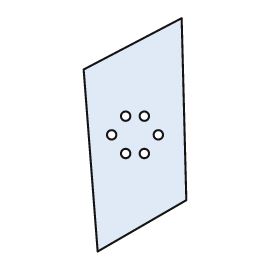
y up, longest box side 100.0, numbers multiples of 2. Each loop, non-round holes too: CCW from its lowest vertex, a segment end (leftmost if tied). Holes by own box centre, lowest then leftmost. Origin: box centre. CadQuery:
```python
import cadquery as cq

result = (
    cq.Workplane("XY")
    .moveTo(-16.0, -50.0)
    .lineTo(22.0, -28.0)
    .lineTo(20.0, 50.0)
    .lineTo(-22.0, 28.0)
    .close()
    .moveTo(-4.0, -8.0)
    .circle(2.0)
    .moveTo(4.0, -8.0)
    .circle(2.0)
    .moveTo(-10.0, 0.0)
    .circle(2.0)
    .moveTo(10.0, 0.0)
    .circle(2.0)
    .moveTo(-4.0, 8.0)
    .circle(2.0)
    .moveTo(4.0, 8.0)
    .circle(2.0)
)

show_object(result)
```